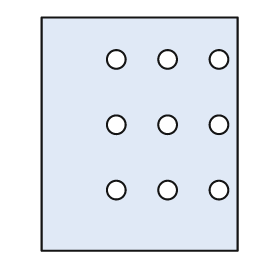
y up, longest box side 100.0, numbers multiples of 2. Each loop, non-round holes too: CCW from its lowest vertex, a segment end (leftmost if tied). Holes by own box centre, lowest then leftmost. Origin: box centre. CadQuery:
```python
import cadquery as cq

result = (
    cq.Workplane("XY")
    .moveTo(-42.0, -50.0)
    .lineTo(42.0, -50.0)
    .lineTo(42.0, 50.0)
    .lineTo(-42.0, 50.0)
    .close()
    .moveTo(-10.0, -24.0)
    .circle(4.0)
    .moveTo(12.0, -24.0)
    .circle(4.0)
    .moveTo(34.0, -24.0)
    .circle(4.0)
    .moveTo(-10.0, 4.0)
    .circle(4.0)
    .moveTo(12.0, 4.0)
    .circle(4.0)
    .moveTo(34.0, 4.0)
    .circle(4.0)
    .moveTo(-10.0, 32.0)
    .circle(4.0)
    .moveTo(12.0, 32.0)
    .circle(4.0)
    .moveTo(34.0, 32.0)
    .circle(4.0)
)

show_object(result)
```